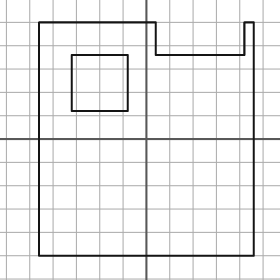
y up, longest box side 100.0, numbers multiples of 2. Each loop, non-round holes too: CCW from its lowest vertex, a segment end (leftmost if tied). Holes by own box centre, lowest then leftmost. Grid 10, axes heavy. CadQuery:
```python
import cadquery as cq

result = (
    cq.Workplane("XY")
    .moveTo(-46.0, -50.0)
    .lineTo(46.0, -50.0)
    .lineTo(46.0, 50.0)
    .lineTo(42.0, 50.0)
    .lineTo(42.0, 36.0)
    .lineTo(4.0, 36.0)
    .lineTo(4.0, 50.0)
    .lineTo(-46.0, 50.0)
    .close()
    .moveTo(-32.0, 12.0)
    .lineTo(-8.0, 12.0)
    .lineTo(-8.0, 36.0)
    .lineTo(-32.0, 36.0)
    .close()
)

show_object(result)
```